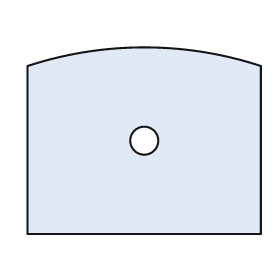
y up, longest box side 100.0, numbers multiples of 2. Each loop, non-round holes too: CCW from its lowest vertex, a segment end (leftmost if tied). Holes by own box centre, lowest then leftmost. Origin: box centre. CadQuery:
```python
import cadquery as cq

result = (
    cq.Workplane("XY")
    .moveTo(-50.0, -40.0)
    .lineTo(50.0, -40.0)
    .lineTo(50.0, 32.0)
    .threePointArc((0.0, 40.0), (-50.0, 32.0))
    .close()
    .moveTo(0.0, 0.0)
    .circle(6.0)
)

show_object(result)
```